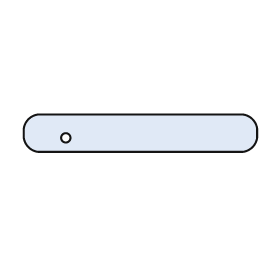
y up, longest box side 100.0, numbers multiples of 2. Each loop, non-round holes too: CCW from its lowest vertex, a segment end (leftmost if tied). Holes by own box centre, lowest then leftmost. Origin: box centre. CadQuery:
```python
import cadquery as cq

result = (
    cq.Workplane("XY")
    .moveTo(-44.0, -8.0)
    .lineTo(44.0, -8.0)
    .threePointArc((48.0, -6.0), (50.0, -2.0))
    .lineTo(50.0, 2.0)
    .threePointArc((48.0, 6.0), (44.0, 8.0))
    .lineTo(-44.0, 8.0)
    .threePointArc((-48.0, 6.0), (-50.0, 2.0))
    .lineTo(-50.0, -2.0)
    .threePointArc((-48.0, -6.0), (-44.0, -8.0))
    .close()
    .moveTo(-32.0, -2.0)
    .circle(2.0)
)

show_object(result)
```